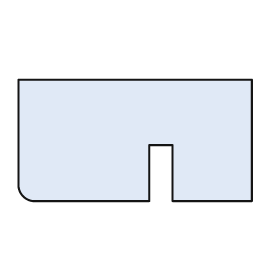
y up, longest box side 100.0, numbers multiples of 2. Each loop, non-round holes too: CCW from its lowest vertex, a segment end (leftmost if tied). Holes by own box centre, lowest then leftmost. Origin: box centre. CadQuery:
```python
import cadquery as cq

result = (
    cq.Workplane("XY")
    .moveTo(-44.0, -26.0)
    .lineTo(6.0, -26.0)
    .lineTo(6.0, -2.0)
    .lineTo(16.0, -2.0)
    .lineTo(16.0, -26.0)
    .lineTo(50.0, -26.0)
    .lineTo(50.0, 26.0)
    .lineTo(-50.0, 26.0)
    .lineTo(-50.0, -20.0)
    .threePointArc((-48.0, -24.0), (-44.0, -26.0))
    .close()
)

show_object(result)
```